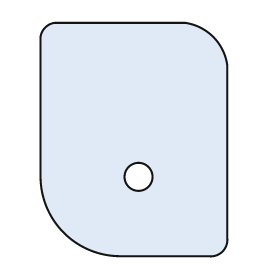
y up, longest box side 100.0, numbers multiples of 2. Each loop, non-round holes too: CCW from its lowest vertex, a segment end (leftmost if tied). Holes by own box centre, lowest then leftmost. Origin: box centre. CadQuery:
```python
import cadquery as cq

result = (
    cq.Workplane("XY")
    .moveTo(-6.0, -50.0)
    .lineTo(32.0, -50.0)
    .threePointArc((38.0, -48.0), (40.0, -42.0))
    .lineTo(40.0, 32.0)
    .threePointArc((34.0, 44.0), (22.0, 50.0))
    .lineTo(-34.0, 50.0)
    .threePointArc((-38.0, 48.0), (-40.0, 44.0))
    .lineTo(-40.0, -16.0)
    .threePointArc((-30.0, -40.0), (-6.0, -50.0))
    .close()
    .moveTo(2.0, -16.0)
    .circle(6.0)
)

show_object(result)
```